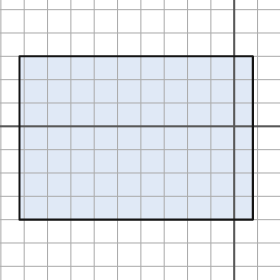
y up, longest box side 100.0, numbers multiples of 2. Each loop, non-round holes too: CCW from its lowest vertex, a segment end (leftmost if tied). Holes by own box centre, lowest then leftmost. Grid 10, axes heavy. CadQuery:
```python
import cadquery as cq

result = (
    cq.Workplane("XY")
    .moveTo(-92.0, -40.0)
    .lineTo(8.0, -40.0)
    .lineTo(8.0, 30.0)
    .lineTo(-92.0, 30.0)
    .close()
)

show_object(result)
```